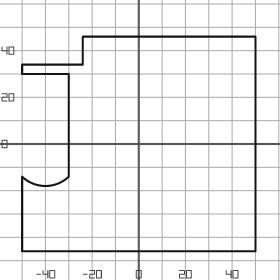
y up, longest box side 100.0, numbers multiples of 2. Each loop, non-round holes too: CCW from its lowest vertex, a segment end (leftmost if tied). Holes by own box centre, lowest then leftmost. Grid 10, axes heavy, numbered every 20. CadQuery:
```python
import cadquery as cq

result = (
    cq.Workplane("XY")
    .moveTo(-50.0, -46.0)
    .lineTo(50.0, -46.0)
    .lineTo(50.0, 46.0)
    .lineTo(-24.0, 46.0)
    .lineTo(-24.0, 34.0)
    .lineTo(-50.0, 34.0)
    .lineTo(-50.0, 30.0)
    .lineTo(-30.0, 30.0)
    .lineTo(-30.0, -14.0)
    .threePointArc((-40.0, -18.0), (-50.0, -14.0))
    .close()
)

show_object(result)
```